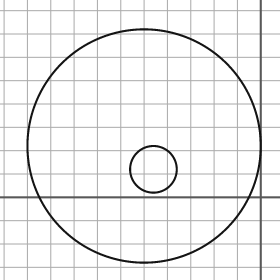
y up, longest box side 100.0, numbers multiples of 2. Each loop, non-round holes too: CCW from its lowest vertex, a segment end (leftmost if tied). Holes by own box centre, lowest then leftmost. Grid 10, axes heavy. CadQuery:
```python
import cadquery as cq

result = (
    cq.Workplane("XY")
    .moveTo(-50.0, 22.0)
    .circle(50.0)
    .moveTo(-46.0, 12.0)
    .circle(10.0)
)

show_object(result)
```